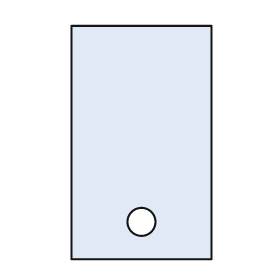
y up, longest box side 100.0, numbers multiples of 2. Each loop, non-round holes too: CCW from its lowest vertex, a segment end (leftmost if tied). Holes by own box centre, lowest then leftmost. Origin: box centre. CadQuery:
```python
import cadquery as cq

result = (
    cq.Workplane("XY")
    .moveTo(-30.0, -50.0)
    .lineTo(30.0, -50.0)
    .lineTo(30.0, 50.0)
    .lineTo(-30.0, 50.0)
    .close()
    .moveTo(0.0, -34.0)
    .circle(6.0)
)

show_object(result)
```